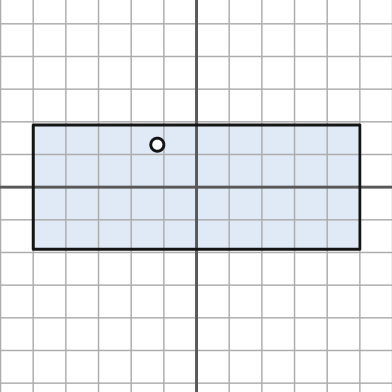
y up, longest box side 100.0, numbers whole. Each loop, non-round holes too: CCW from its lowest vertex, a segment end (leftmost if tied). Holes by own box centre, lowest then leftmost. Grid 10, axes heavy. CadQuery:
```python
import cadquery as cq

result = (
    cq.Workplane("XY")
    .moveTo(-50.0, -19.0)
    .lineTo(50.0, -19.0)
    .lineTo(50.0, 19.0)
    .lineTo(-50.0, 19.0)
    .close()
    .moveTo(-12.0, 13.0)
    .circle(2.0)
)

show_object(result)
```